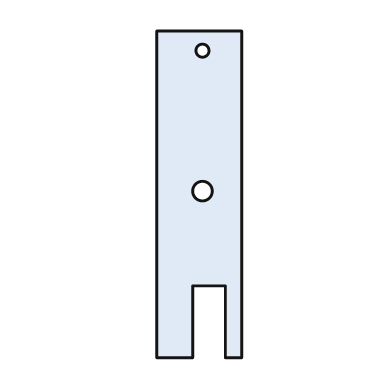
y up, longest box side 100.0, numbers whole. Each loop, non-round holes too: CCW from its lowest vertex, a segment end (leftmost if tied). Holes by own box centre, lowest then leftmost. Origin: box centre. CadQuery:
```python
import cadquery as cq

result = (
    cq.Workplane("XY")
    .moveTo(-13.0, -50.0)
    .lineTo(-2.0, -50.0)
    .lineTo(-2.0, -28.0)
    .lineTo(8.0, -28.0)
    .lineTo(8.0, -50.0)
    .lineTo(13.0, -50.0)
    .lineTo(13.0, 50.0)
    .lineTo(-13.0, 50.0)
    .close()
    .moveTo(1.0, 1.0)
    .circle(3.0)
    .moveTo(1.0, 44.0)
    .circle(2.0)
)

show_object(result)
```